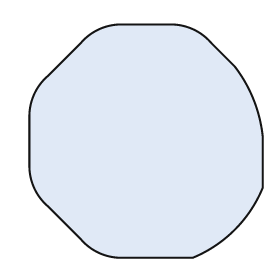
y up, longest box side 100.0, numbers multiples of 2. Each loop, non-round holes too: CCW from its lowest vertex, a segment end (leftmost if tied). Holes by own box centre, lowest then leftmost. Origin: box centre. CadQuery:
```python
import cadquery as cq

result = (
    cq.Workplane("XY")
    .moveTo(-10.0, -50.0)
    .lineTo(20.0, -50.0)
    .threePointArc((38.0, -38.0), (50.0, -20.0))
    .lineTo(50.0, 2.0)
    .threePointArc((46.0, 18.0), (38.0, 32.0))
    .lineTo(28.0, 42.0)
    .threePointArc((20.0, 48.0), (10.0, 50.0))
    .lineTo(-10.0, 50.0)
    .threePointArc((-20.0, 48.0), (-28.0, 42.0))
    .lineTo(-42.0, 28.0)
    .threePointArc((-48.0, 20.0), (-50.0, 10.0))
    .lineTo(-50.0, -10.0)
    .threePointArc((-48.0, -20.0), (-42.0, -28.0))
    .lineTo(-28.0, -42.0)
    .threePointArc((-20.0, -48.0), (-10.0, -50.0))
    .close()
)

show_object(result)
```